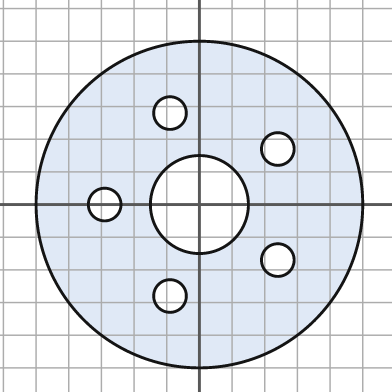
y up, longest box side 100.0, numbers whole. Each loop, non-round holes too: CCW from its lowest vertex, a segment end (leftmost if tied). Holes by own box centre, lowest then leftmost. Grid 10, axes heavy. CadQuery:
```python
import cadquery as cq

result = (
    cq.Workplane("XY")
    .moveTo(0.0, 0.0)
    .circle(50.0)
    .moveTo(-9.0, -28.0)
    .circle(5.0)
    .moveTo(24.0, -17.0)
    .circle(5.0)
    .moveTo(-29.0, 0.0)
    .circle(5.0)
    .moveTo(0.0, 0.0)
    .circle(15.0)
    .moveTo(24.0, 17.0)
    .circle(5.0)
    .moveTo(-9.0, 28.0)
    .circle(5.0)
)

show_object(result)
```